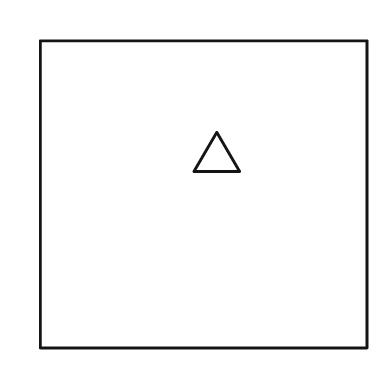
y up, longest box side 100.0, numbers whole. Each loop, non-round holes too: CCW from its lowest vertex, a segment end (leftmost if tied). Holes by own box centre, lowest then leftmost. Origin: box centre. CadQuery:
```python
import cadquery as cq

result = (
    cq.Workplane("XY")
    .moveTo(-50.0, -47.0)
    .lineTo(50.0, -47.0)
    .lineTo(50.0, 47.0)
    .lineTo(-50.0, 47.0)
    .close()
    .moveTo(-3.0, 7.0)
    .lineTo(11.0, 7.0)
    .lineTo(4.0, 19.0)
    .close()
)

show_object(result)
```